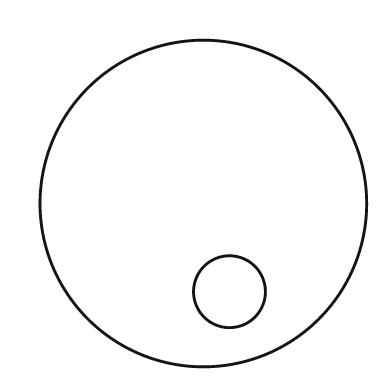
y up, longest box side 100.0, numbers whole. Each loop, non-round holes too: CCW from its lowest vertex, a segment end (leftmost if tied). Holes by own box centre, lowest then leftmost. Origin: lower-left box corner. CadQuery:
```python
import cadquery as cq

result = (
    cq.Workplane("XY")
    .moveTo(50.0, 50.0)
    .circle(50.0)
    .moveTo(58.0, 23.0)
    .circle(11.0)
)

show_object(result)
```